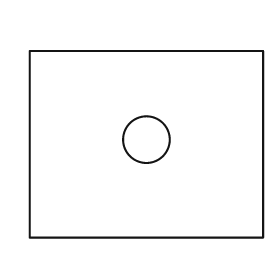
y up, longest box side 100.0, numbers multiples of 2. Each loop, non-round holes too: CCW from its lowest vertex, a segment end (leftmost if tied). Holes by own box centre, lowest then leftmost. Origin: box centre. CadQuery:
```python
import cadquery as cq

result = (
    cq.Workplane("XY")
    .moveTo(-50.0, -40.0)
    .lineTo(50.0, -40.0)
    .lineTo(50.0, 40.0)
    .lineTo(-50.0, 40.0)
    .close()
    .moveTo(0.0, 2.0)
    .circle(10.0)
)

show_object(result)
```